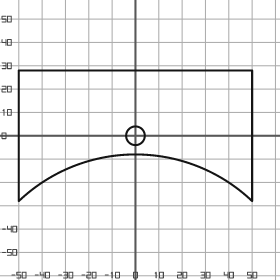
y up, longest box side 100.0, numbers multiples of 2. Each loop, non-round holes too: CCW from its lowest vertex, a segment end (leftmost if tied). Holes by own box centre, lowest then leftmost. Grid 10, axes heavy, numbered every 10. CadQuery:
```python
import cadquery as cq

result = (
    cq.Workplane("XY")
    .moveTo(-50.0, -28.0)
    .threePointArc((0.0, -8.0), (50.0, -28.0))
    .lineTo(50.0, 28.0)
    .lineTo(-50.0, 28.0)
    .close()
    .moveTo(0.0, 0.0)
    .circle(4.0)
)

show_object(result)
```